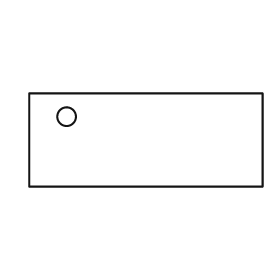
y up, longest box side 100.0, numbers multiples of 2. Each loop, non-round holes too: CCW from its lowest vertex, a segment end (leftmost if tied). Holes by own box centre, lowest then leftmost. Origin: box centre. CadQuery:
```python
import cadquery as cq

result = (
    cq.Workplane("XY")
    .moveTo(-50.0, -20.0)
    .lineTo(50.0, -20.0)
    .lineTo(50.0, 20.0)
    .lineTo(-50.0, 20.0)
    .close()
    .moveTo(-34.0, 10.0)
    .circle(4.0)
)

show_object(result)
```